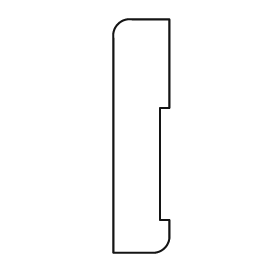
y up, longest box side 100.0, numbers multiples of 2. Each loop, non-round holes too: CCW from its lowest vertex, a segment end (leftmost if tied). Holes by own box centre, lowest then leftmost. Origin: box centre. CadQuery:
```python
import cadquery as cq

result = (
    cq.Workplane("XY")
    .moveTo(-12.0, -50.0)
    .lineTo(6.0, -50.0)
    .threePointArc((10.0, -48.0), (12.0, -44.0))
    .lineTo(12.0, -36.0)
    .lineTo(8.0, -36.0)
    .lineTo(8.0, 12.0)
    .lineTo(12.0, 12.0)
    .lineTo(12.0, 50.0)
    .lineTo(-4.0, 50.0)
    .threePointArc((-10.0, 48.0), (-12.0, 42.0))
    .close()
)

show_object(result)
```